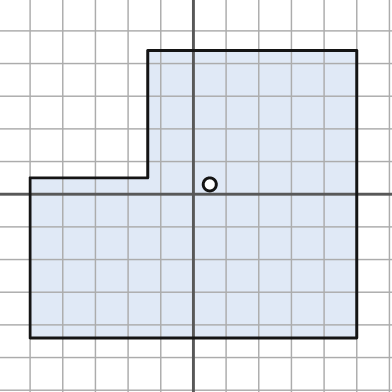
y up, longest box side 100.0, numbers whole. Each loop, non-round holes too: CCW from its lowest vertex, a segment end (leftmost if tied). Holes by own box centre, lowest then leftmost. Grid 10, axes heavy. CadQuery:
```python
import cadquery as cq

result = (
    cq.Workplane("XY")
    .moveTo(-50.0, -44.0)
    .lineTo(50.0, -44.0)
    .lineTo(50.0, 44.0)
    .lineTo(-14.0, 44.0)
    .lineTo(-14.0, 5.0)
    .lineTo(-50.0, 5.0)
    .close()
    .moveTo(5.0, 3.0)
    .circle(2.0)
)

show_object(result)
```